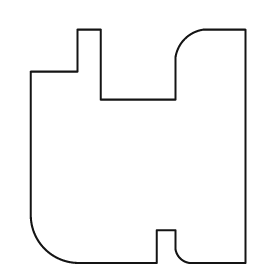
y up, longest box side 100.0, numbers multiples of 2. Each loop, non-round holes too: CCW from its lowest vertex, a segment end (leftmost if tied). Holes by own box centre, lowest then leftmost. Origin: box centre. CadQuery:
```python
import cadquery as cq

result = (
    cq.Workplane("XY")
    .moveTo(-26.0, -50.0)
    .lineTo(8.0, -50.0)
    .lineTo(8.0, -36.0)
    .lineTo(16.0, -36.0)
    .lineTo(16.0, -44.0)
    .threePointArc((18.0, -48.0), (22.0, -50.0))
    .lineTo(46.0, -50.0)
    .lineTo(46.0, 50.0)
    .lineTo(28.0, 50.0)
    .threePointArc((20.0, 46.0), (16.0, 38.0))
    .lineTo(16.0, 20.0)
    .lineTo(-16.0, 20.0)
    .lineTo(-16.0, 50.0)
    .lineTo(-26.0, 50.0)
    .lineTo(-26.0, 32.0)
    .lineTo(-46.0, 32.0)
    .lineTo(-46.0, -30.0)
    .threePointArc((-40.0, -44.0), (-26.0, -50.0))
    .close()
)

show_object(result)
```